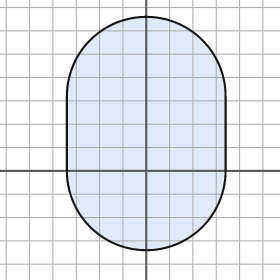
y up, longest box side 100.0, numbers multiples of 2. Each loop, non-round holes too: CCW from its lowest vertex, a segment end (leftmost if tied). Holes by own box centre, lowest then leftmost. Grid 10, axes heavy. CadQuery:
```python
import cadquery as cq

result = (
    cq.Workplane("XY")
    .moveTo(-34.0, 0.0)
    .threePointArc((0.0, -34.0), (34.0, 0.0))
    .lineTo(34.0, 32.0)
    .threePointArc((0.0, 66.0), (-34.0, 32.0))
    .close()
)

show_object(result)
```